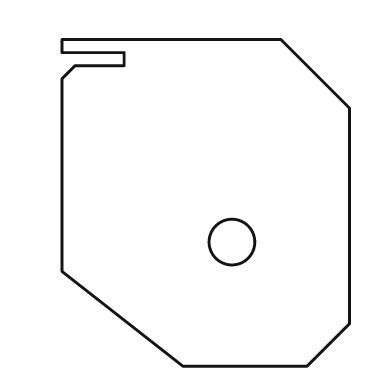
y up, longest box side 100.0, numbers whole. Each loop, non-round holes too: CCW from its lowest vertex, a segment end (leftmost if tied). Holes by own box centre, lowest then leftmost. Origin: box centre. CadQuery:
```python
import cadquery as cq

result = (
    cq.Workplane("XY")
    .moveTo(-7.0, -50.0)
    .lineTo(31.0, -50.0)
    .lineTo(44.0, -37.0)
    .lineTo(44.0, 29.0)
    .lineTo(23.0, 50.0)
    .lineTo(-44.0, 50.0)
    .lineTo(-44.0, 46.0)
    .lineTo(-25.0, 46.0)
    .lineTo(-25.0, 42.0)
    .lineTo(-40.0, 42.0)
    .lineTo(-44.0, 38.0)
    .lineTo(-44.0, -21.0)
    .close()
    .moveTo(8.0, -12.0)
    .circle(7.0)
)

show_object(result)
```